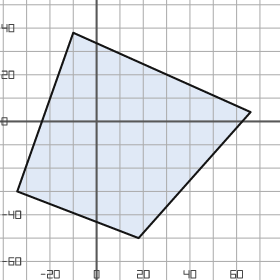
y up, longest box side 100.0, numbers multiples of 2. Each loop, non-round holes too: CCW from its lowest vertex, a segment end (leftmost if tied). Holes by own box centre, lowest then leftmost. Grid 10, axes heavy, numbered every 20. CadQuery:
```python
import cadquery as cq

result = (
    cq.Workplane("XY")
    .moveTo(18.0, -50.0)
    .lineTo(66.0, 4.0)
    .lineTo(-10.0, 38.0)
    .lineTo(-34.0, -30.0)
    .close()
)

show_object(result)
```